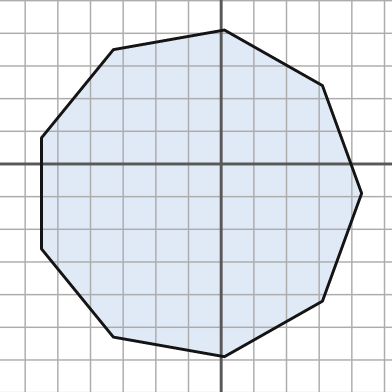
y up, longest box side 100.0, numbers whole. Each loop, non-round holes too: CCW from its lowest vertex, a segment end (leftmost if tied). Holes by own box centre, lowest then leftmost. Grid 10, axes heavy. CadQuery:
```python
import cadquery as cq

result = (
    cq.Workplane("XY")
    .moveTo(1.0, -59.0)
    .lineTo(31.0, -42.0)
    .lineTo(43.0, -9.0)
    .lineTo(31.0, 24.0)
    .lineTo(1.0, 41.0)
    .lineTo(-33.0, 35.0)
    .lineTo(-55.0, 8.0)
    .lineTo(-55.0, -26.0)
    .lineTo(-33.0, -53.0)
    .close()
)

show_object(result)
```